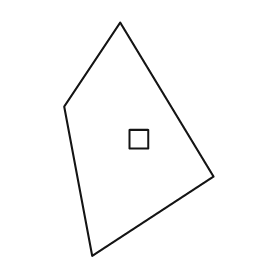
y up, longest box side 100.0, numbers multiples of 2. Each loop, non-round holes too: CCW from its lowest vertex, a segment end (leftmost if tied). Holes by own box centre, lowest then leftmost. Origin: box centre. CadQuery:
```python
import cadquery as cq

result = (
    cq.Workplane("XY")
    .moveTo(-20.0, -50.0)
    .lineTo(32.0, -16.0)
    .lineTo(-8.0, 50.0)
    .lineTo(-32.0, 14.0)
    .close()
    .moveTo(-4.0, -4.0)
    .lineTo(4.0, -4.0)
    .lineTo(4.0, 4.0)
    .lineTo(-4.0, 4.0)
    .close()
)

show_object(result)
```